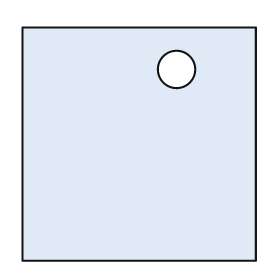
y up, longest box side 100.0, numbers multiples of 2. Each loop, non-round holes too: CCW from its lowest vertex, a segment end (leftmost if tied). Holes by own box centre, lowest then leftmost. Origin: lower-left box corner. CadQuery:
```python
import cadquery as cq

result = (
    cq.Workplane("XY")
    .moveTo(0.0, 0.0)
    .lineTo(100.0, 0.0)
    .lineTo(100.0, 100.0)
    .lineTo(0.0, 100.0)
    .close()
    .moveTo(66.0, 82.0)
    .circle(8.0)
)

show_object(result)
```